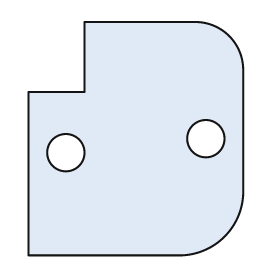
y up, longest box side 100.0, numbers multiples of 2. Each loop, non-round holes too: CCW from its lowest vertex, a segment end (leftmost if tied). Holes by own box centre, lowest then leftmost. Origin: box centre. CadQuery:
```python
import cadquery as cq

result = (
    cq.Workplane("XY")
    .moveTo(-46.0, -50.0)
    .lineTo(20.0, -50.0)
    .threePointArc((38.0, -42.0), (46.0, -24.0))
    .lineTo(46.0, 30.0)
    .threePointArc((40.0, 44.0), (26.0, 50.0))
    .lineTo(-22.0, 50.0)
    .lineTo(-22.0, 20.0)
    .lineTo(-46.0, 20.0)
    .close()
    .moveTo(-30.0, -6.0)
    .circle(8.0)
    .moveTo(30.0, 0.0)
    .circle(8.0)
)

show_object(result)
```